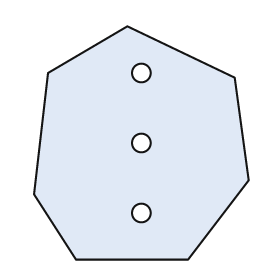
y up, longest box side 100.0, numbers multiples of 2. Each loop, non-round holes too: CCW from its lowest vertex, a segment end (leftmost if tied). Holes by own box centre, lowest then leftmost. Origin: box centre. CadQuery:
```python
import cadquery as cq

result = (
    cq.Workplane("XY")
    .moveTo(-28.0, -50.0)
    .lineTo(20.0, -50.0)
    .lineTo(46.0, -16.0)
    .lineTo(40.0, 28.0)
    .lineTo(-6.0, 50.0)
    .lineTo(-40.0, 30.0)
    .lineTo(-46.0, -22.0)
    .close()
    .moveTo(0.0, -30.0)
    .circle(4.0)
    .moveTo(0.0, 0.0)
    .circle(4.0)
    .moveTo(0.0, 30.0)
    .circle(4.0)
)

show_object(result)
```